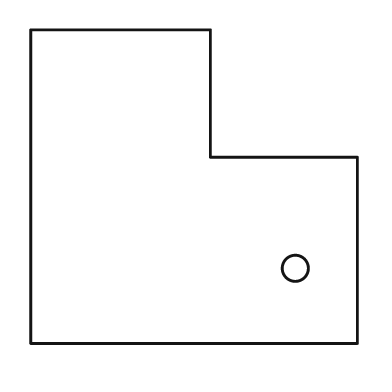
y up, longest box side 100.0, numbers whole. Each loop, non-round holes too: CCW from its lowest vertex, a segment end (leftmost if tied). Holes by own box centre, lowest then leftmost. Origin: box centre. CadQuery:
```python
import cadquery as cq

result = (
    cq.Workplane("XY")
    .moveTo(-50.0, -48.0)
    .lineTo(50.0, -48.0)
    .lineTo(50.0, 9.0)
    .lineTo(5.0, 9.0)
    .lineTo(5.0, 48.0)
    .lineTo(-50.0, 48.0)
    .close()
    .moveTo(31.0, -25.0)
    .circle(4.0)
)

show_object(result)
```